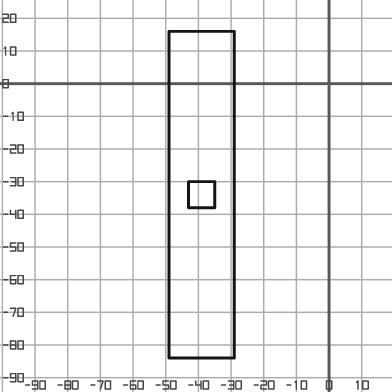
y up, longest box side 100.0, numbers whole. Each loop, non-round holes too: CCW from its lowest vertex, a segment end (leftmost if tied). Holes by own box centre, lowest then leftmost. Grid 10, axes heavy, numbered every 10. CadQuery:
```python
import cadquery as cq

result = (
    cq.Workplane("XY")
    .moveTo(-49.0, -84.0)
    .lineTo(-29.0, -84.0)
    .lineTo(-29.0, 16.0)
    .lineTo(-49.0, 16.0)
    .close()
    .moveTo(-43.0, -38.0)
    .lineTo(-35.0, -38.0)
    .lineTo(-35.0, -30.0)
    .lineTo(-43.0, -30.0)
    .close()
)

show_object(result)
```